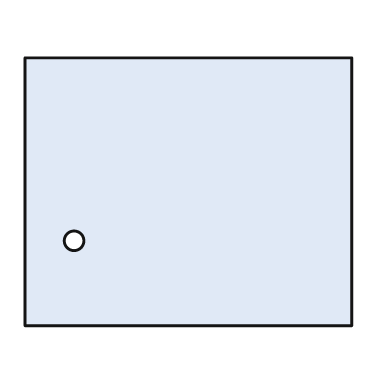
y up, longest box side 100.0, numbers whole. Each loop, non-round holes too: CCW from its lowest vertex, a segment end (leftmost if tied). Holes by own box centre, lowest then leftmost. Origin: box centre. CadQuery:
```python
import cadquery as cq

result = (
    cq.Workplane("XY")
    .moveTo(-50.0, -41.0)
    .lineTo(50.0, -41.0)
    .lineTo(50.0, 41.0)
    .lineTo(-50.0, 41.0)
    .close()
    .moveTo(-35.0, -15.0)
    .circle(3.0)
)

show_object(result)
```